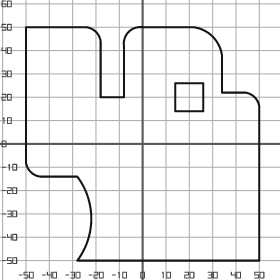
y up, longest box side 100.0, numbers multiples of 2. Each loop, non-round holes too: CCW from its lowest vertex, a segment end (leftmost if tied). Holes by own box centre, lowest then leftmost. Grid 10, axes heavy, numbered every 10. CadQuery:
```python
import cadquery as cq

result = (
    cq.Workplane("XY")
    .moveTo(-28.0, -50.0)
    .lineTo(50.0, -50.0)
    .lineTo(50.0, 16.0)
    .threePointArc((48.0, 20.0), (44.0, 22.0))
    .lineTo(34.0, 22.0)
    .lineTo(34.0, 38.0)
    .threePointArc((30.0, 46.0), (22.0, 50.0))
    .lineTo(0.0, 50.0)
    .threePointArc((-6.0, 48.0), (-8.0, 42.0))
    .lineTo(-8.0, 20.0)
    .lineTo(-18.0, 20.0)
    .lineTo(-18.0, 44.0)
    .threePointArc((-20.0, 48.0), (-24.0, 50.0))
    .lineTo(-50.0, 50.0)
    .lineTo(-50.0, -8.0)
    .threePointArc((-48.0, -12.0), (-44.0, -14.0))
    .lineTo(-28.0, -14.0)
    .threePointArc((-22.0, -32.0), (-28.0, -50.0))
    .close()
    .moveTo(14.0, 14.0)
    .lineTo(26.0, 14.0)
    .lineTo(26.0, 26.0)
    .lineTo(14.0, 26.0)
    .close()
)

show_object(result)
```